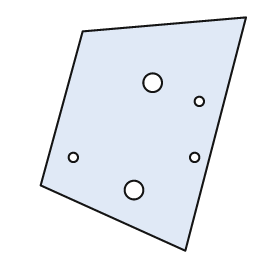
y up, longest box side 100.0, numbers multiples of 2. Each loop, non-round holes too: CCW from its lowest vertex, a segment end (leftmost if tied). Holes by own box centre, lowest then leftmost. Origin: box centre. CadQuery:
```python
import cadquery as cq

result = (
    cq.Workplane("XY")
    .moveTo(18.0, -50.0)
    .lineTo(44.0, 50.0)
    .lineTo(-26.0, 44.0)
    .lineTo(-44.0, -22.0)
    .close()
    .moveTo(-4.0, -24.0)
    .circle(4.0)
    .moveTo(-30.0, -10.0)
    .circle(2.0)
    .moveTo(22.0, -10.0)
    .circle(2.0)
    .moveTo(24.0, 14.0)
    .circle(2.0)
    .moveTo(4.0, 22.0)
    .circle(4.0)
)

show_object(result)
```